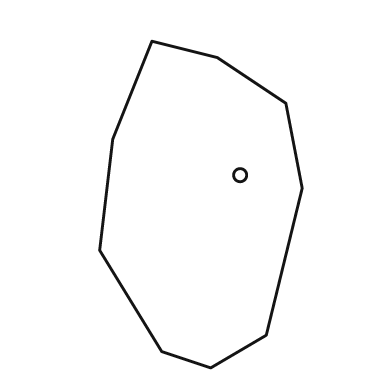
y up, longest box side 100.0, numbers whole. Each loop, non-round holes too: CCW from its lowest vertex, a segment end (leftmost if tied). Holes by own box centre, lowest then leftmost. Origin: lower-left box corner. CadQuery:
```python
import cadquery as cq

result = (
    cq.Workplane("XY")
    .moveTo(34.0, 0.0)
    .lineTo(51.0, 10.0)
    .lineTo(62.0, 55.0)
    .lineTo(57.0, 81.0)
    .lineTo(36.0, 95.0)
    .lineTo(16.0, 100.0)
    .lineTo(4.0, 70.0)
    .lineTo(0.0, 36.0)
    .lineTo(19.0, 5.0)
    .close()
    .moveTo(43.0, 59.0)
    .circle(2.0)
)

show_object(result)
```